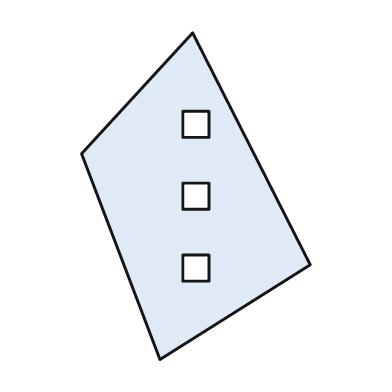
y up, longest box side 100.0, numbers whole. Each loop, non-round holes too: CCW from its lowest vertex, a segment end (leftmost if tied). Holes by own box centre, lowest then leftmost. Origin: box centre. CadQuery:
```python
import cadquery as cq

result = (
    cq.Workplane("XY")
    .moveTo(-11.0, -50.0)
    .lineTo(35.0, -21.0)
    .lineTo(-1.0, 50.0)
    .lineTo(-35.0, 13.0)
    .close()
    .moveTo(-4.0, -26.0)
    .lineTo(4.0, -26.0)
    .lineTo(4.0, -18.0)
    .lineTo(-4.0, -18.0)
    .close()
    .moveTo(-4.0, -4.0)
    .lineTo(4.0, -4.0)
    .lineTo(4.0, 4.0)
    .lineTo(-4.0, 4.0)
    .close()
    .moveTo(-4.0, 18.0)
    .lineTo(4.0, 18.0)
    .lineTo(4.0, 26.0)
    .lineTo(-4.0, 26.0)
    .close()
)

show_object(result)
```